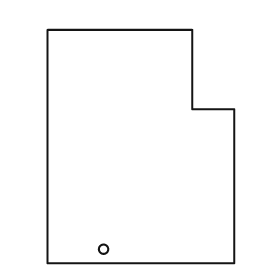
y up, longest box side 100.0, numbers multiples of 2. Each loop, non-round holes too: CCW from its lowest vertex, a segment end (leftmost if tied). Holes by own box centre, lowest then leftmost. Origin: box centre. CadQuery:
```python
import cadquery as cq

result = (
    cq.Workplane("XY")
    .moveTo(-40.0, -50.0)
    .lineTo(40.0, -50.0)
    .lineTo(40.0, 16.0)
    .lineTo(22.0, 16.0)
    .lineTo(22.0, 50.0)
    .lineTo(-40.0, 50.0)
    .close()
    .moveTo(-16.0, -44.0)
    .circle(2.0)
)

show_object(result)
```